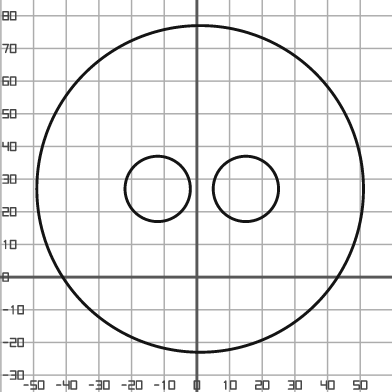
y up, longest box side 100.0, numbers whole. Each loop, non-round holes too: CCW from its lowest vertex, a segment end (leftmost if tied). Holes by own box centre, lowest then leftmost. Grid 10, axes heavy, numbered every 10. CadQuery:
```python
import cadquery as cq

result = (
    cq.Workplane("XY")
    .moveTo(1.0, 27.0)
    .circle(50.0)
    .moveTo(-12.0, 27.0)
    .circle(10.0)
    .moveTo(15.0, 27.0)
    .circle(10.0)
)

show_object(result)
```